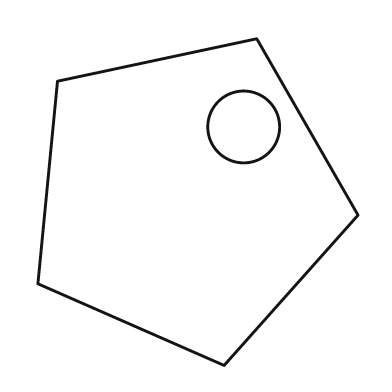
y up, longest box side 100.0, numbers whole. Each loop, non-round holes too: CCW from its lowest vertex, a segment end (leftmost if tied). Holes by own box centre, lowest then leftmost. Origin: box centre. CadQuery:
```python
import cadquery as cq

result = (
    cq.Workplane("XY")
    .moveTo(8.0, -50.0)
    .lineTo(49.0, -4.0)
    .lineTo(18.0, 50.0)
    .lineTo(-43.0, 37.0)
    .lineTo(-49.0, -25.0)
    .close()
    .moveTo(14.0, 23.0)
    .circle(11.0)
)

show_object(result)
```